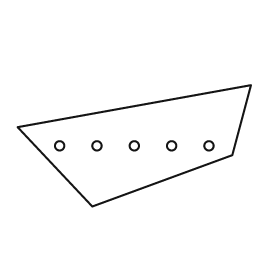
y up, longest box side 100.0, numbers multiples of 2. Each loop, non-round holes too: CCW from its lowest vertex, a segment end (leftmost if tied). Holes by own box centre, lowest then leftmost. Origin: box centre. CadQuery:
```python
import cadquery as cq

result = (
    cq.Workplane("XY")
    .moveTo(-18.0, -26.0)
    .lineTo(42.0, -4.0)
    .lineTo(50.0, 26.0)
    .lineTo(-50.0, 8.0)
    .close()
    .moveTo(-32.0, 0.0)
    .circle(2.0)
    .moveTo(-16.0, 0.0)
    .circle(2.0)
    .moveTo(0.0, 0.0)
    .circle(2.0)
    .moveTo(16.0, 0.0)
    .circle(2.0)
    .moveTo(32.0, 0.0)
    .circle(2.0)
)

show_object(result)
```